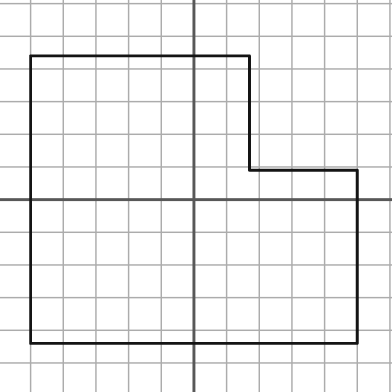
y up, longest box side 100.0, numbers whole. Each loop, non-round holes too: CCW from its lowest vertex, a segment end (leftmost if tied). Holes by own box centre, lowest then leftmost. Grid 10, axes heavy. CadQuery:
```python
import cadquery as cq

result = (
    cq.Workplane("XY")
    .moveTo(-50.0, -44.0)
    .lineTo(50.0, -44.0)
    .lineTo(50.0, 9.0)
    .lineTo(17.0, 9.0)
    .lineTo(17.0, 44.0)
    .lineTo(-50.0, 44.0)
    .close()
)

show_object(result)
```